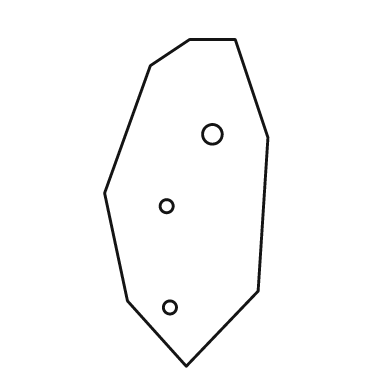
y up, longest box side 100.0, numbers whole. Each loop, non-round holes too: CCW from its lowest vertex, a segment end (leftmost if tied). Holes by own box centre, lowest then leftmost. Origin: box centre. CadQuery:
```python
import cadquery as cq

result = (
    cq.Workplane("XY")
    .moveTo(0.0, -50.0)
    .lineTo(22.0, -27.0)
    .lineTo(25.0, 20.0)
    .lineTo(15.0, 50.0)
    .lineTo(1.0, 50.0)
    .lineTo(-11.0, 42.0)
    .lineTo(-25.0, 3.0)
    .lineTo(-18.0, -30.0)
    .close()
    .moveTo(-5.0, -32.0)
    .circle(2.0)
    .moveTo(-6.0, -1.0)
    .circle(2.0)
    .moveTo(8.0, 21.0)
    .circle(3.0)
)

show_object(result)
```